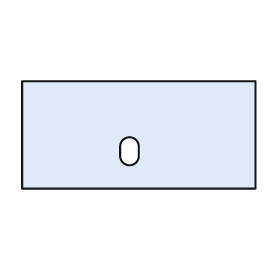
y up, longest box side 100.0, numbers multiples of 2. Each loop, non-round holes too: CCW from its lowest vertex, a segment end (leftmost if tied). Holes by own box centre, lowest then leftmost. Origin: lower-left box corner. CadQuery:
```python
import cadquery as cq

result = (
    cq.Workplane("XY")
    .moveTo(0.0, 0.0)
    .lineTo(100.0, 0.0)
    .lineTo(100.0, 46.0)
    .lineTo(0.0, 46.0)
    .close()
    .moveTo(42.0, 14.0)
    .threePointArc((46.0, 10.0), (50.0, 14.0))
    .lineTo(50.0, 18.0)
    .threePointArc((46.0, 22.0), (42.0, 18.0))
    .close()
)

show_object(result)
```